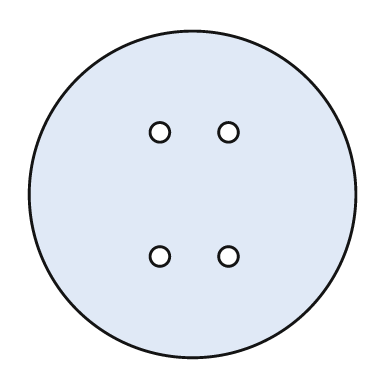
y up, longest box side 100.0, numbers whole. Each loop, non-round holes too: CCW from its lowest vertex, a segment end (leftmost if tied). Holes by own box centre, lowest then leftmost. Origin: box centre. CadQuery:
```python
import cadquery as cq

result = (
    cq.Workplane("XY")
    .moveTo(0.0, 0.0)
    .circle(50.0)
    .moveTo(-10.0, -19.0)
    .circle(3.0)
    .moveTo(11.0, -19.0)
    .circle(3.0)
    .moveTo(-10.0, 19.0)
    .circle(3.0)
    .moveTo(11.0, 19.0)
    .circle(3.0)
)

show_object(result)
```